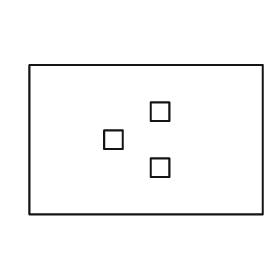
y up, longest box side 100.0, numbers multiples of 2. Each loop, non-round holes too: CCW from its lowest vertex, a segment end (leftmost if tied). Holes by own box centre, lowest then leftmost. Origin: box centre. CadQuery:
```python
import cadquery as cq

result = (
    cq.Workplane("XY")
    .moveTo(-50.0, -32.0)
    .lineTo(50.0, -32.0)
    .lineTo(50.0, 32.0)
    .lineTo(-50.0, 32.0)
    .close()
    .moveTo(2.0, -16.0)
    .lineTo(10.0, -16.0)
    .lineTo(10.0, -8.0)
    .lineTo(2.0, -8.0)
    .close()
    .moveTo(-18.0, -4.0)
    .lineTo(-10.0, -4.0)
    .lineTo(-10.0, 4.0)
    .lineTo(-18.0, 4.0)
    .close()
    .moveTo(2.0, 8.0)
    .lineTo(10.0, 8.0)
    .lineTo(10.0, 16.0)
    .lineTo(2.0, 16.0)
    .close()
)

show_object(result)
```